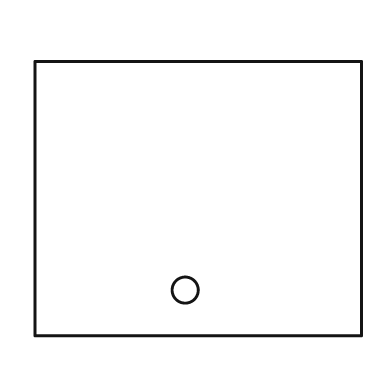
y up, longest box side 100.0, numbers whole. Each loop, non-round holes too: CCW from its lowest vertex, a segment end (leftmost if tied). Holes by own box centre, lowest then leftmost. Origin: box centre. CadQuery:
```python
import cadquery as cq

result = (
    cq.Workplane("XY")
    .moveTo(-50.0, -42.0)
    .lineTo(50.0, -42.0)
    .lineTo(50.0, 42.0)
    .lineTo(-50.0, 42.0)
    .close()
    .moveTo(-4.0, -28.0)
    .circle(4.0)
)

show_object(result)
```